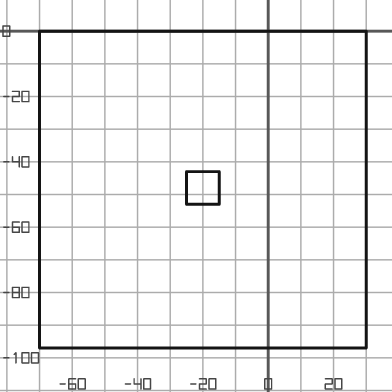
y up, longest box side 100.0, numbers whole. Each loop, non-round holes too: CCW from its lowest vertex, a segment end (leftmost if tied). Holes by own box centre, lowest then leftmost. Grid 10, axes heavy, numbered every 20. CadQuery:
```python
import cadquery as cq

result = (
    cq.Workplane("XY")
    .moveTo(-70.0, -97.0)
    .lineTo(30.0, -97.0)
    .lineTo(30.0, 0.0)
    .lineTo(-70.0, 0.0)
    .close()
    .moveTo(-25.0, -53.0)
    .lineTo(-15.0, -53.0)
    .lineTo(-15.0, -43.0)
    .lineTo(-25.0, -43.0)
    .close()
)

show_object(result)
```